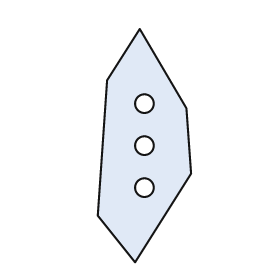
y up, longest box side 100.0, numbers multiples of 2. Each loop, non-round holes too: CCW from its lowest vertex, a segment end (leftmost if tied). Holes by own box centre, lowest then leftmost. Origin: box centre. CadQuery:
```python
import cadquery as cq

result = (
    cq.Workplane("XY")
    .moveTo(-4.0, -50.0)
    .lineTo(20.0, -12.0)
    .lineTo(18.0, 16.0)
    .lineTo(-2.0, 50.0)
    .lineTo(-16.0, 28.0)
    .lineTo(-20.0, -30.0)
    .close()
    .moveTo(0.0, -18.0)
    .circle(4.0)
    .moveTo(0.0, 0.0)
    .circle(4.0)
    .moveTo(0.0, 18.0)
    .circle(4.0)
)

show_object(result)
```